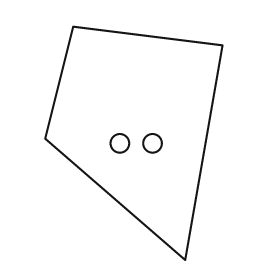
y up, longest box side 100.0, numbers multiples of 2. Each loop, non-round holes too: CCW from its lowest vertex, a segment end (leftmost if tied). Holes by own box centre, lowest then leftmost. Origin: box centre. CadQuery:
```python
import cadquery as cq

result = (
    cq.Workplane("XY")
    .moveTo(22.0, -50.0)
    .lineTo(38.0, 42.0)
    .lineTo(-26.0, 50.0)
    .lineTo(-38.0, 2.0)
    .close()
    .moveTo(-6.0, 0.0)
    .circle(4.0)
    .moveTo(8.0, 0.0)
    .circle(4.0)
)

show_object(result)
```